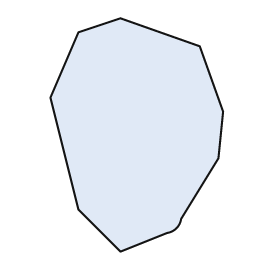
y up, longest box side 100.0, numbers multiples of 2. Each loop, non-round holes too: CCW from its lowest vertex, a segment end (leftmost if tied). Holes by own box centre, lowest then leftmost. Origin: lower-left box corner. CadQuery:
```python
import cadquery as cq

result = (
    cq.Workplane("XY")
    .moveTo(30.0, 0.0)
    .lineTo(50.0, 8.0)
    .threePointArc((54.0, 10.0), (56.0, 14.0))
    .lineTo(72.0, 40.0)
    .lineTo(74.0, 60.0)
    .lineTo(64.0, 88.0)
    .lineTo(30.0, 100.0)
    .lineTo(12.0, 94.0)
    .lineTo(0.0, 66.0)
    .lineTo(12.0, 18.0)
    .close()
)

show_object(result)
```